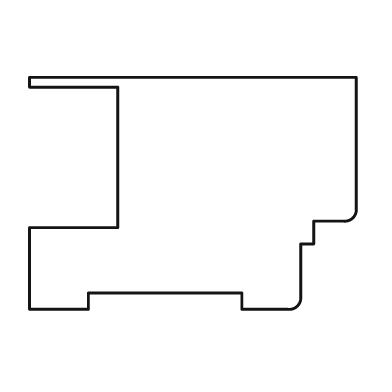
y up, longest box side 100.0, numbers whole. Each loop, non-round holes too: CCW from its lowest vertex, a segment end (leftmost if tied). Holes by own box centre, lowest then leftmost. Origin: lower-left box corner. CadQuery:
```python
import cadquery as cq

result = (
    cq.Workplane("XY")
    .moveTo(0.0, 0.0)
    .lineTo(18.0, 0.0)
    .lineTo(18.0, 5.0)
    .lineTo(65.0, 5.0)
    .lineTo(65.0, 0.0)
    .lineTo(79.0, 0.0)
    .threePointArc((82.0, 1.0), (83.0, 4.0))
    .lineTo(83.0, 20.0)
    .lineTo(87.0, 20.0)
    .lineTo(87.0, 27.0)
    .lineTo(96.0, 27.0)
    .threePointArc((99.0, 28.0), (100.0, 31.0))
    .lineTo(100.0, 71.0)
    .lineTo(0.0, 71.0)
    .lineTo(0.0, 68.0)
    .lineTo(27.0, 68.0)
    .lineTo(27.0, 25.0)
    .lineTo(0.0, 25.0)
    .close()
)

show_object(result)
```